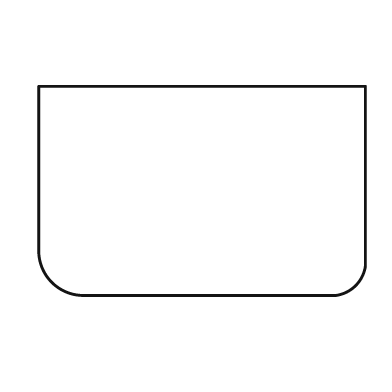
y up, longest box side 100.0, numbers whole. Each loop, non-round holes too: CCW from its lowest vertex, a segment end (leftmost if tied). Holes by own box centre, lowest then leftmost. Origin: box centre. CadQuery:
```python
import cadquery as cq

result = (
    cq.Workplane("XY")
    .moveTo(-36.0, -32.0)
    .lineTo(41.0, -32.0)
    .threePointArc((47.0, -29.0), (50.0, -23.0))
    .lineTo(50.0, 32.0)
    .lineTo(-50.0, 32.0)
    .lineTo(-50.0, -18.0)
    .threePointArc((-46.0, -28.0), (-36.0, -32.0))
    .close()
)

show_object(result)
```